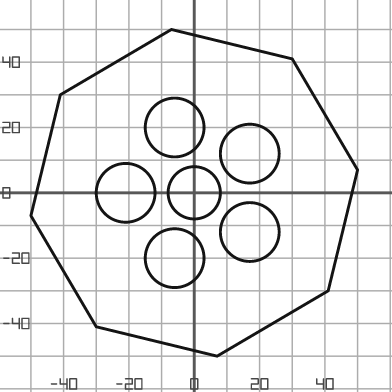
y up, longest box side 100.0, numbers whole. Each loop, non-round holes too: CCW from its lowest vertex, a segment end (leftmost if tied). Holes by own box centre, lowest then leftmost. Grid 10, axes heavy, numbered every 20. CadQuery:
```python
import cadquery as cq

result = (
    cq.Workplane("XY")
    .moveTo(7.0, -50.0)
    .lineTo(41.0, -30.0)
    .lineTo(50.0, 7.0)
    .lineTo(30.0, 41.0)
    .lineTo(-7.0, 50.0)
    .lineTo(-41.0, 30.0)
    .lineTo(-50.0, -7.0)
    .lineTo(-30.0, -41.0)
    .close()
    .moveTo(-6.0, -20.0)
    .circle(9.0)
    .moveTo(17.0, -12.0)
    .circle(9.0)
    .moveTo(-21.0, 0.0)
    .circle(9.0)
    .moveTo(0.0, 0.0)
    .circle(8.0)
    .moveTo(17.0, 12.0)
    .circle(9.0)
    .moveTo(-6.0, 20.0)
    .circle(9.0)
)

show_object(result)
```